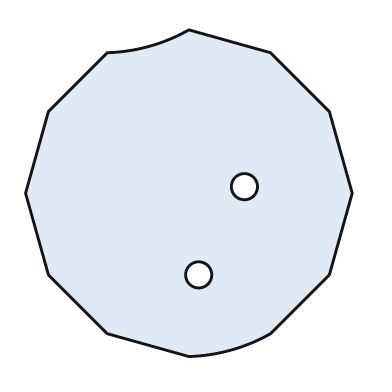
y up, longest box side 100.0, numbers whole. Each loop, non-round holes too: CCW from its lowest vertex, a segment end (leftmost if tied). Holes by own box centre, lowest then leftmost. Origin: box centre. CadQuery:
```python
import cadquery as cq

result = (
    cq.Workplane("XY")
    .moveTo(0.0, -50.0)
    .threePointArc((13.0, -48.0), (25.0, -43.0))
    .lineTo(43.0, -25.0)
    .lineTo(50.0, 0.0)
    .lineTo(43.0, 25.0)
    .lineTo(25.0, 43.0)
    .lineTo(0.0, 50.0)
    .threePointArc((-12.0, 45.0), (-25.0, 43.0))
    .lineTo(-43.0, 25.0)
    .lineTo(-50.0, 0.0)
    .lineTo(-43.0, -25.0)
    .lineTo(-25.0, -43.0)
    .close()
    .moveTo(3.0, -25.0)
    .circle(4.0)
    .moveTo(17.0, 2.0)
    .circle(4.0)
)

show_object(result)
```